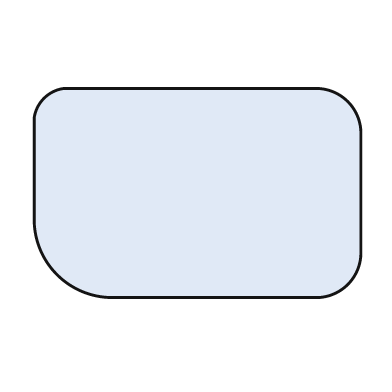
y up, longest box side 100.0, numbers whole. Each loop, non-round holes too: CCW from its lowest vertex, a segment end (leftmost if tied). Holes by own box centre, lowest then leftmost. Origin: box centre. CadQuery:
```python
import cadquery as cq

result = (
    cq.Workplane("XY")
    .moveTo(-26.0, -32.0)
    .lineTo(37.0, -32.0)
    .threePointArc((46.0, -28.0), (50.0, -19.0))
    .lineTo(50.0, 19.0)
    .threePointArc((46.0, 28.0), (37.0, 32.0))
    .lineTo(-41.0, 32.0)
    .threePointArc((-47.0, 29.0), (-50.0, 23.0))
    .lineTo(-50.0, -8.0)
    .threePointArc((-43.0, -25.0), (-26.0, -32.0))
    .close()
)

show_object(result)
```